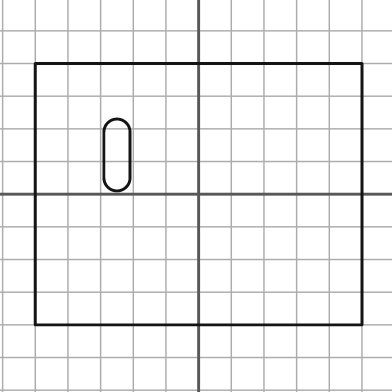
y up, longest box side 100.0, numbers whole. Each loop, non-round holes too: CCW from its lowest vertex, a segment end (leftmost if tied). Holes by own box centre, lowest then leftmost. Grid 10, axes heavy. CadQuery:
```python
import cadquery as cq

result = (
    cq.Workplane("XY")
    .moveTo(-50.0, -40.0)
    .lineTo(50.0, -40.0)
    .lineTo(50.0, 40.0)
    .lineTo(-50.0, 40.0)
    .close()
    .moveTo(-29.0, 5.0)
    .threePointArc((-25.0, 1.0), (-21.0, 5.0))
    .lineTo(-21.0, 19.0)
    .threePointArc((-25.0, 23.0), (-29.0, 19.0))
    .close()
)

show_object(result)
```